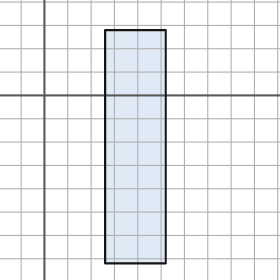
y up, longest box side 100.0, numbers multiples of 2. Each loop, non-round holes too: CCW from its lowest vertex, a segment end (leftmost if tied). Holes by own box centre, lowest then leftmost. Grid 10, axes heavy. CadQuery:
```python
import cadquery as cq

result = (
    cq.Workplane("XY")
    .moveTo(26.0, -72.0)
    .lineTo(52.0, -72.0)
    .lineTo(52.0, 28.0)
    .lineTo(26.0, 28.0)
    .close()
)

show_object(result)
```